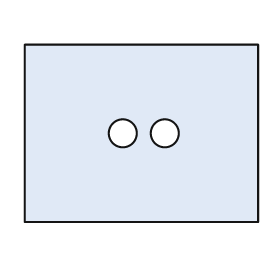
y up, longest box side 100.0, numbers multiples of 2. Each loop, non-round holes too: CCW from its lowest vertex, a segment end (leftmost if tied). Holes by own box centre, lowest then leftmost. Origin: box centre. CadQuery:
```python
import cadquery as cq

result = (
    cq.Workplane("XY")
    .moveTo(-50.0, -38.0)
    .lineTo(50.0, -38.0)
    .lineTo(50.0, 38.0)
    .lineTo(-50.0, 38.0)
    .close()
    .moveTo(-8.0, 0.0)
    .circle(6.0)
    .moveTo(10.0, 0.0)
    .circle(6.0)
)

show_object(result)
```